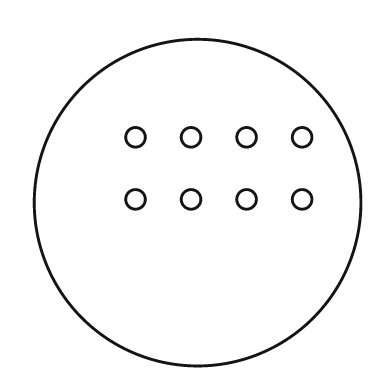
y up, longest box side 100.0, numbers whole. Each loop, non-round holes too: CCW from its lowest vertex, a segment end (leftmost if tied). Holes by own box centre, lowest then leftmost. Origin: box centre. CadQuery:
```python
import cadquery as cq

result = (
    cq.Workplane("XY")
    .moveTo(0.0, 0.0)
    .circle(50.0)
    .moveTo(-19.0, 1.0)
    .circle(3.0)
    .moveTo(-2.0, 1.0)
    .circle(3.0)
    .moveTo(15.0, 1.0)
    .circle(3.0)
    .moveTo(32.0, 1.0)
    .circle(3.0)
    .moveTo(-19.0, 20.0)
    .circle(3.0)
    .moveTo(-2.0, 20.0)
    .circle(3.0)
    .moveTo(15.0, 20.0)
    .circle(3.0)
    .moveTo(32.0, 20.0)
    .circle(3.0)
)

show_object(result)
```